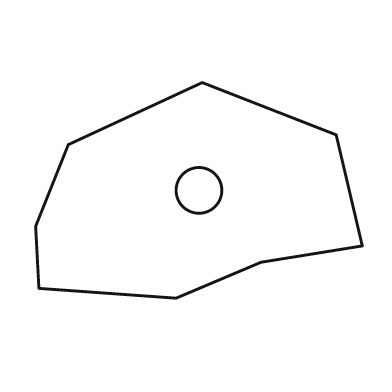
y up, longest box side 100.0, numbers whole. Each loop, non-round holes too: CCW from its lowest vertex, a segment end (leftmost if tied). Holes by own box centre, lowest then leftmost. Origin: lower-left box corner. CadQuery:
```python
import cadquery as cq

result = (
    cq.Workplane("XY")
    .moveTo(43.0, 0.0)
    .lineTo(69.0, 11.0)
    .lineTo(100.0, 16.0)
    .lineTo(92.0, 50.0)
    .lineTo(51.0, 66.0)
    .lineTo(10.0, 47.0)
    .lineTo(0.0, 22.0)
    .lineTo(1.0, 3.0)
    .close()
    .moveTo(50.0, 33.0)
    .circle(7.0)
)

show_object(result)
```